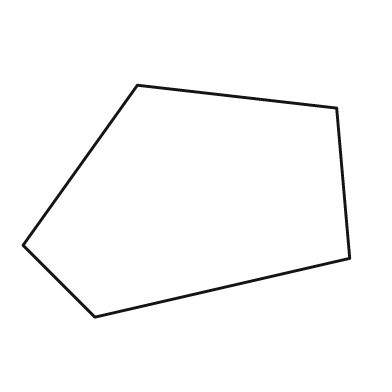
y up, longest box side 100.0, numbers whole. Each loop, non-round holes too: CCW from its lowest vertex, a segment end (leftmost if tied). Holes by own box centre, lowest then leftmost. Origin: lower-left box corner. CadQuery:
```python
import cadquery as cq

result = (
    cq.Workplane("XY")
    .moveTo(22.0, 0.0)
    .lineTo(100.0, 18.0)
    .lineTo(96.0, 64.0)
    .lineTo(35.0, 71.0)
    .lineTo(0.0, 22.0)
    .close()
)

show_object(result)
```